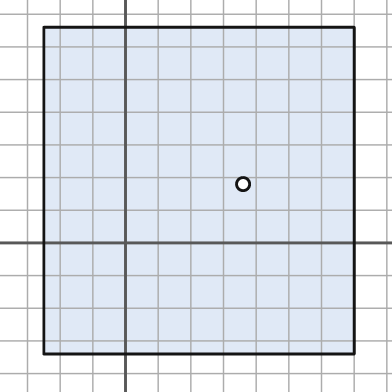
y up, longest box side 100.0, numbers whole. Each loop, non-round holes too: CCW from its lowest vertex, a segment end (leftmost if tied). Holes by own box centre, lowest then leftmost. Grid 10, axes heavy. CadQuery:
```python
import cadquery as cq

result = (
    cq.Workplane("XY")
    .moveTo(-25.0, -34.0)
    .lineTo(70.0, -34.0)
    .lineTo(70.0, 66.0)
    .lineTo(-25.0, 66.0)
    .close()
    .moveTo(36.0, 18.0)
    .circle(2.0)
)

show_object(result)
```